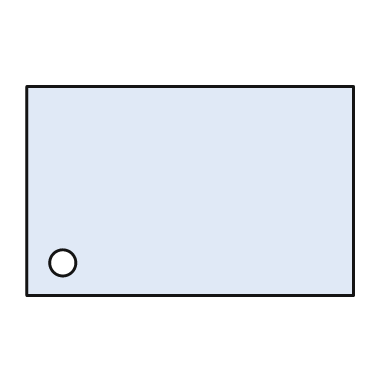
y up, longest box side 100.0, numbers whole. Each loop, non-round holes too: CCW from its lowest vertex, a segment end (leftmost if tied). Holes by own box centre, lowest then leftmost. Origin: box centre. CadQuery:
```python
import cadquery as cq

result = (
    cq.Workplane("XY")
    .moveTo(-50.0, -32.0)
    .lineTo(50.0, -32.0)
    .lineTo(50.0, 32.0)
    .lineTo(-50.0, 32.0)
    .close()
    .moveTo(-39.0, -22.0)
    .circle(4.0)
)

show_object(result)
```